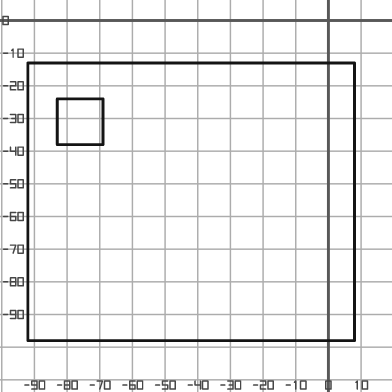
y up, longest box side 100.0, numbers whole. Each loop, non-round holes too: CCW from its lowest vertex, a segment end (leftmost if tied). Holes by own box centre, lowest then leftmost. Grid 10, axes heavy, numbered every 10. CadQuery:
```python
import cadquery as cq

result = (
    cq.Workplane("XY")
    .moveTo(-92.0, -98.0)
    .lineTo(8.0, -98.0)
    .lineTo(8.0, -13.0)
    .lineTo(-92.0, -13.0)
    .close()
    .moveTo(-83.0, -38.0)
    .lineTo(-69.0, -38.0)
    .lineTo(-69.0, -24.0)
    .lineTo(-83.0, -24.0)
    .close()
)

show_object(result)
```